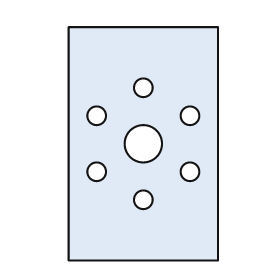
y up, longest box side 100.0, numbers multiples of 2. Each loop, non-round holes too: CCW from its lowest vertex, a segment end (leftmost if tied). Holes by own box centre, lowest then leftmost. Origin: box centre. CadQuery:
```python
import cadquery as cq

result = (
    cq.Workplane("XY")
    .moveTo(-32.0, -50.0)
    .lineTo(32.0, -50.0)
    .lineTo(32.0, 50.0)
    .lineTo(-32.0, 50.0)
    .close()
    .moveTo(0.0, -24.0)
    .circle(4.0)
    .moveTo(-20.0, -12.0)
    .circle(4.0)
    .moveTo(20.0, -12.0)
    .circle(4.0)
    .moveTo(0.0, 0.0)
    .circle(8.0)
    .moveTo(-20.0, 12.0)
    .circle(4.0)
    .moveTo(20.0, 12.0)
    .circle(4.0)
    .moveTo(0.0, 24.0)
    .circle(4.0)
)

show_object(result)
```